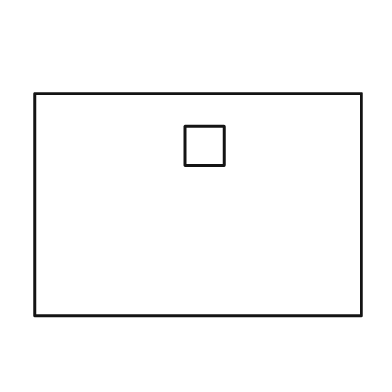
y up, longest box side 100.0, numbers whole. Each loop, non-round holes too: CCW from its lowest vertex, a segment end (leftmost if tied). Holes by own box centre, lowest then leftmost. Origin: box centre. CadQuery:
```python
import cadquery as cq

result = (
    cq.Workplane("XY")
    .moveTo(-50.0, -34.0)
    .lineTo(50.0, -34.0)
    .lineTo(50.0, 34.0)
    .lineTo(-50.0, 34.0)
    .close()
    .moveTo(-4.0, 12.0)
    .lineTo(8.0, 12.0)
    .lineTo(8.0, 24.0)
    .lineTo(-4.0, 24.0)
    .close()
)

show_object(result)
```